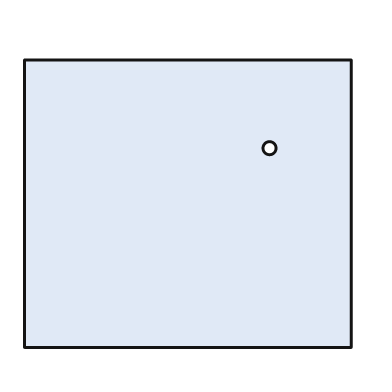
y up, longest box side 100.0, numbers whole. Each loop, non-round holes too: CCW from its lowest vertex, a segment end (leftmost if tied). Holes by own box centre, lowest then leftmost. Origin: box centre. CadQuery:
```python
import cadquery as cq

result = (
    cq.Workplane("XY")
    .moveTo(-50.0, -44.0)
    .lineTo(50.0, -44.0)
    .lineTo(50.0, 44.0)
    .lineTo(-50.0, 44.0)
    .close()
    .moveTo(25.0, 17.0)
    .circle(2.0)
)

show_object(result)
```